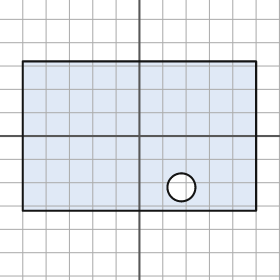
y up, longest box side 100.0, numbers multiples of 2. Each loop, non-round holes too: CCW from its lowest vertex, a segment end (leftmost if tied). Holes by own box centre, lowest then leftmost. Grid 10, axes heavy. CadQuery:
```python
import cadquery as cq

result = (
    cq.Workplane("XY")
    .moveTo(-50.0, -32.0)
    .lineTo(50.0, -32.0)
    .lineTo(50.0, 32.0)
    .lineTo(-50.0, 32.0)
    .close()
    .moveTo(18.0, -22.0)
    .circle(6.0)
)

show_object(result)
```